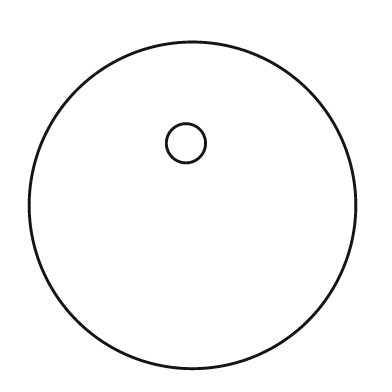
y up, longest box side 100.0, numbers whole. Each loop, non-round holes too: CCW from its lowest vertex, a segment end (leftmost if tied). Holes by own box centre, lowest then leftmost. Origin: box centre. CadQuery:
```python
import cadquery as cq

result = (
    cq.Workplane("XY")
    .moveTo(0.0, 0.0)
    .circle(50.0)
    .moveTo(-2.0, 19.0)
    .circle(6.0)
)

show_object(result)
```